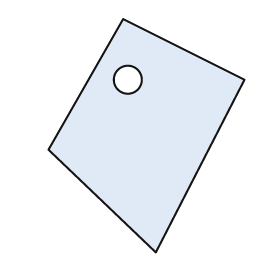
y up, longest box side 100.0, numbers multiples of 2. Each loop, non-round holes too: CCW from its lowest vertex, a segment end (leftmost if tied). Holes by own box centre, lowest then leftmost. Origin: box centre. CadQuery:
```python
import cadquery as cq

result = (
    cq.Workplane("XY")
    .moveTo(4.0, -50.0)
    .lineTo(42.0, 24.0)
    .lineTo(-10.0, 50.0)
    .lineTo(-42.0, -6.0)
    .close()
    .moveTo(-8.0, 24.0)
    .circle(6.0)
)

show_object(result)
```